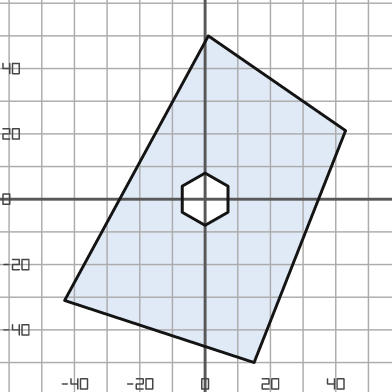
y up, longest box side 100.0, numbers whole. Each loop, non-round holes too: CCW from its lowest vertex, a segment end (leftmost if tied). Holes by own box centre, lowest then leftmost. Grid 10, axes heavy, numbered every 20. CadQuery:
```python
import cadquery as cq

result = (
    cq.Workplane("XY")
    .moveTo(15.0, -50.0)
    .lineTo(43.0, 21.0)
    .lineTo(1.0, 50.0)
    .lineTo(-43.0, -31.0)
    .close()
    .moveTo(0.0, -8.0)
    .lineTo(7.0, -4.0)
    .lineTo(7.0, 4.0)
    .lineTo(0.0, 8.0)
    .lineTo(-7.0, 4.0)
    .lineTo(-7.0, -4.0)
    .close()
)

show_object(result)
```